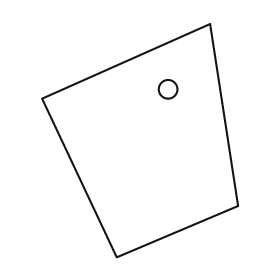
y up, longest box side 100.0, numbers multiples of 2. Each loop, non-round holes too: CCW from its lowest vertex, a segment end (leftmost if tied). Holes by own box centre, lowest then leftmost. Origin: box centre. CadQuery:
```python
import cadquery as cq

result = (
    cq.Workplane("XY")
    .moveTo(-10.0, -50.0)
    .lineTo(42.0, -28.0)
    .lineTo(30.0, 50.0)
    .lineTo(-42.0, 18.0)
    .close()
    .moveTo(12.0, 22.0)
    .circle(4.0)
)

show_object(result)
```